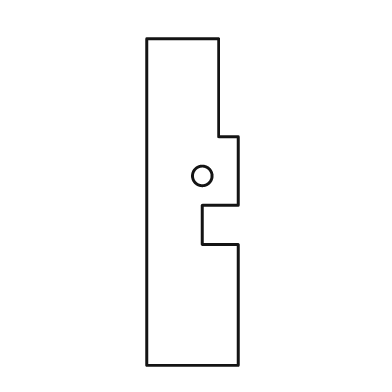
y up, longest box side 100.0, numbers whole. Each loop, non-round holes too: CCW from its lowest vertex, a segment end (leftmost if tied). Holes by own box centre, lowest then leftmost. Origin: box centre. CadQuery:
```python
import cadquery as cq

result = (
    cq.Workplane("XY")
    .moveTo(-14.0, -50.0)
    .lineTo(14.0, -50.0)
    .lineTo(14.0, -13.0)
    .lineTo(3.0, -13.0)
    .lineTo(3.0, -1.0)
    .lineTo(14.0, -1.0)
    .lineTo(14.0, 20.0)
    .lineTo(8.0, 20.0)
    .lineTo(8.0, 50.0)
    .lineTo(-14.0, 50.0)
    .close()
    .moveTo(3.0, 8.0)
    .circle(3.0)
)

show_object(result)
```